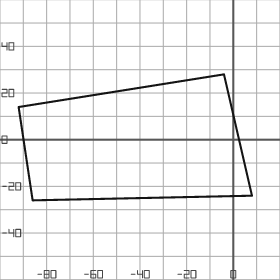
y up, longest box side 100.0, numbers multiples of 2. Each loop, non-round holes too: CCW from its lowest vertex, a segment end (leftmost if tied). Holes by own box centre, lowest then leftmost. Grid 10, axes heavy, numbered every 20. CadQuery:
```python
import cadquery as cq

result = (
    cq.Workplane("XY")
    .moveTo(-86.0, -26.0)
    .lineTo(8.0, -24.0)
    .lineTo(-4.0, 28.0)
    .lineTo(-92.0, 14.0)
    .close()
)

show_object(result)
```